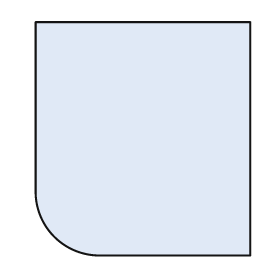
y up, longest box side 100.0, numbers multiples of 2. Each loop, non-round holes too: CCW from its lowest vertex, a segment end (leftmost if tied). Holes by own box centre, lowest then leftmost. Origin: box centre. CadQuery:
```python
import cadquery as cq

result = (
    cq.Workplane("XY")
    .moveTo(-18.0, -50.0)
    .lineTo(46.0, -50.0)
    .lineTo(46.0, 50.0)
    .lineTo(-46.0, 50.0)
    .lineTo(-46.0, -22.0)
    .threePointArc((-38.0, -42.0), (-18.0, -50.0))
    .close()
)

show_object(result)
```